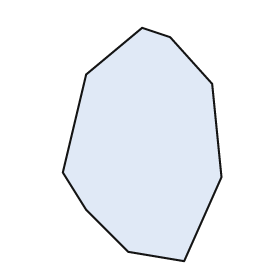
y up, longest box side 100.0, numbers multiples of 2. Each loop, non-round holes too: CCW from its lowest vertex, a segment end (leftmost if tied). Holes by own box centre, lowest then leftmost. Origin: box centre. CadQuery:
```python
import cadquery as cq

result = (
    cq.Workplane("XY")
    .moveTo(18.0, -50.0)
    .lineTo(34.0, -14.0)
    .lineTo(30.0, 26.0)
    .lineTo(12.0, 46.0)
    .lineTo(0.0, 50.0)
    .lineTo(-24.0, 30.0)
    .lineTo(-34.0, -12.0)
    .lineTo(-24.0, -28.0)
    .lineTo(-6.0, -46.0)
    .close()
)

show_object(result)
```